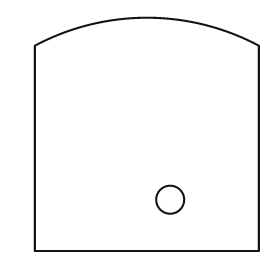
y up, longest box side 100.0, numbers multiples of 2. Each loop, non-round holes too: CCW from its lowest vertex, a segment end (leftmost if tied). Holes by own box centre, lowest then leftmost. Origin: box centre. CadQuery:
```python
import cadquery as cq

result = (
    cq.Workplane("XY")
    .moveTo(-48.0, -50.0)
    .lineTo(48.0, -50.0)
    .lineTo(48.0, 38.0)
    .threePointArc((0.0, 50.0), (-48.0, 38.0))
    .close()
    .moveTo(10.0, -28.0)
    .circle(6.0)
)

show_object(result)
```